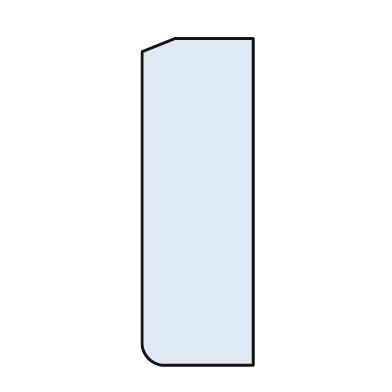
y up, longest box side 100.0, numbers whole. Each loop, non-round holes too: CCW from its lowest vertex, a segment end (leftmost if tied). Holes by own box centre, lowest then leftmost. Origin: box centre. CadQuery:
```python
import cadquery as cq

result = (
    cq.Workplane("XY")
    .moveTo(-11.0, -50.0)
    .lineTo(17.0, -50.0)
    .lineTo(17.0, 50.0)
    .lineTo(-7.0, 50.0)
    .lineTo(-17.0, 46.0)
    .lineTo(-17.0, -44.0)
    .threePointArc((-15.0, -48.0), (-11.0, -50.0))
    .close()
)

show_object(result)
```